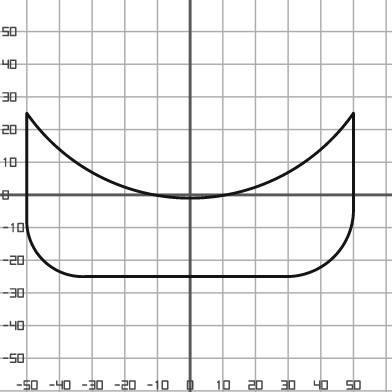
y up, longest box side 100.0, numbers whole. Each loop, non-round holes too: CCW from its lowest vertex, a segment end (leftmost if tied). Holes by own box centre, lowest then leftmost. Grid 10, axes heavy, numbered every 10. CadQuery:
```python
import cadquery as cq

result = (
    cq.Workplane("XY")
    .moveTo(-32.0, -25.0)
    .lineTo(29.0, -25.0)
    .threePointArc((44.0, -19.0), (50.0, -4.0))
    .lineTo(50.0, 25.0)
    .threePointArc((0.0, -1.0), (-50.0, 25.0))
    .lineTo(-50.0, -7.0)
    .threePointArc((-45.0, -20.0), (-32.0, -25.0))
    .close()
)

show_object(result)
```